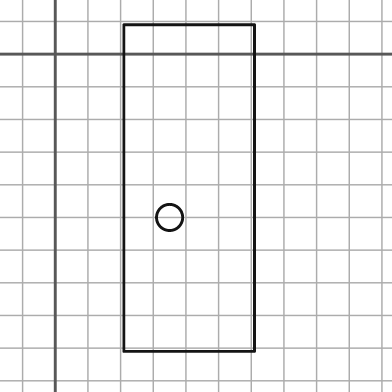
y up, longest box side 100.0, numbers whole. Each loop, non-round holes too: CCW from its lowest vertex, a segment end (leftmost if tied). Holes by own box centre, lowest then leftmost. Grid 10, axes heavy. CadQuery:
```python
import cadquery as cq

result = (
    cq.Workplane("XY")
    .moveTo(21.0, -91.0)
    .lineTo(61.0, -91.0)
    .lineTo(61.0, 9.0)
    .lineTo(21.0, 9.0)
    .close()
    .moveTo(35.0, -50.0)
    .circle(4.0)
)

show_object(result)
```